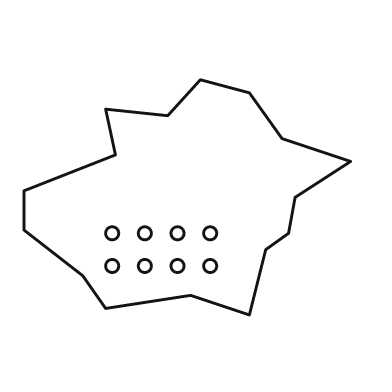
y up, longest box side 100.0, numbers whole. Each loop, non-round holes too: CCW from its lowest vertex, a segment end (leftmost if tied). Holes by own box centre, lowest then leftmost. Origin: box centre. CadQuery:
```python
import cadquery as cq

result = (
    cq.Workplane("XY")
    .moveTo(19.0, -36.0)
    .lineTo(24.0, -16.0)
    .lineTo(31.0, -11.0)
    .lineTo(33.0, 0.0)
    .lineTo(50.0, 11.0)
    .lineTo(29.0, 18.0)
    .lineTo(19.0, 32.0)
    .lineTo(4.0, 36.0)
    .lineTo(-6.0, 25.0)
    .lineTo(-25.0, 27.0)
    .lineTo(-22.0, 13.0)
    .lineTo(-50.0, 2.0)
    .lineTo(-50.0, -10.0)
    .lineTo(-32.0, -24.0)
    .lineTo(-25.0, -34.0)
    .lineTo(1.0, -30.0)
    .close()
    .moveTo(-23.0, -21.0)
    .circle(2.0)
    .moveTo(-13.0, -21.0)
    .circle(2.0)
    .moveTo(-3.0, -21.0)
    .circle(2.0)
    .moveTo(7.0, -21.0)
    .circle(2.0)
    .moveTo(-23.0, -11.0)
    .circle(2.0)
    .moveTo(-13.0, -11.0)
    .circle(2.0)
    .moveTo(-3.0, -11.0)
    .circle(2.0)
    .moveTo(7.0, -11.0)
    .circle(2.0)
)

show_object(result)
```